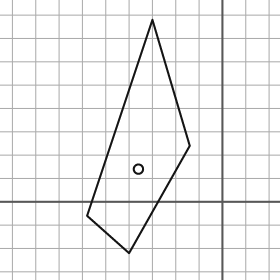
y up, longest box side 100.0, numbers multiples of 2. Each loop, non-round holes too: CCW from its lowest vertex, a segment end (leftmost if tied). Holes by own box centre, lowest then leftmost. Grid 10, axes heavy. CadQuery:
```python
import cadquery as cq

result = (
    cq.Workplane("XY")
    .moveTo(-40.0, -22.0)
    .lineTo(-14.0, 24.0)
    .lineTo(-30.0, 78.0)
    .lineTo(-58.0, -6.0)
    .close()
    .moveTo(-36.0, 14.0)
    .circle(2.0)
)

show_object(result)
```